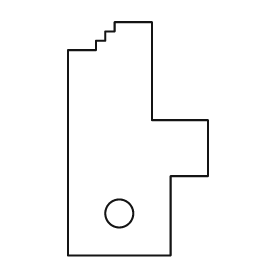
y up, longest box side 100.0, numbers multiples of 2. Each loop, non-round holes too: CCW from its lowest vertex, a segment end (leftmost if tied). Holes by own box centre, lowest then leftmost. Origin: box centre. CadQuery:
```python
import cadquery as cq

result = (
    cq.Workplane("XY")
    .moveTo(-30.0, -50.0)
    .lineTo(14.0, -50.0)
    .lineTo(14.0, -16.0)
    .lineTo(30.0, -16.0)
    .lineTo(30.0, 8.0)
    .lineTo(6.0, 8.0)
    .lineTo(6.0, 50.0)
    .lineTo(-10.0, 50.0)
    .lineTo(-10.0, 46.0)
    .lineTo(-14.0, 46.0)
    .lineTo(-14.0, 42.0)
    .lineTo(-18.0, 42.0)
    .lineTo(-18.0, 38.0)
    .lineTo(-30.0, 38.0)
    .close()
    .moveTo(-8.0, -32.0)
    .circle(6.0)
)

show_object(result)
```